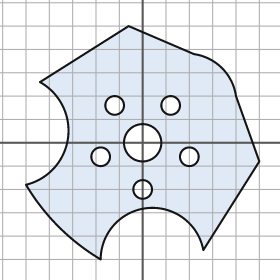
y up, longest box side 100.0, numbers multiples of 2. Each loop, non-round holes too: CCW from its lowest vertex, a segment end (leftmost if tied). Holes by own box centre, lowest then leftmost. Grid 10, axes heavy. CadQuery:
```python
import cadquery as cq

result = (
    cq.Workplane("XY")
    .moveTo(-18.0, -50.0)
    .threePointArc((2.0, -28.0), (26.0, -46.0))
    .lineTo(50.0, -8.0)
    .lineTo(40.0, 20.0)
    .threePointArc((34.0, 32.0), (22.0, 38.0))
    .lineTo(-6.0, 50.0)
    .lineTo(-44.0, 26.0)
    .threePointArc((-32.0, 2.0), (-50.0, -18.0))
    .threePointArc((-36.0, -36.0), (-18.0, -50.0))
    .close()
    .moveTo(0.0, -20.0)
    .circle(4.0)
    .moveTo(-18.0, -6.0)
    .circle(4.0)
    .moveTo(20.0, -6.0)
    .circle(4.0)
    .moveTo(0.0, 0.0)
    .circle(8.0)
    .moveTo(-12.0, 16.0)
    .circle(4.0)
    .moveTo(12.0, 16.0)
    .circle(4.0)
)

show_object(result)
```